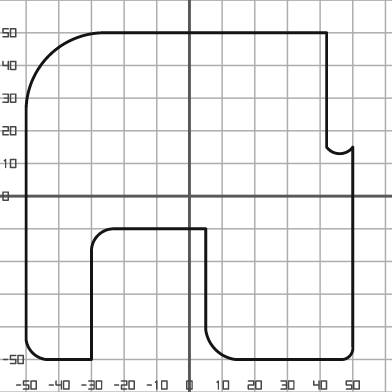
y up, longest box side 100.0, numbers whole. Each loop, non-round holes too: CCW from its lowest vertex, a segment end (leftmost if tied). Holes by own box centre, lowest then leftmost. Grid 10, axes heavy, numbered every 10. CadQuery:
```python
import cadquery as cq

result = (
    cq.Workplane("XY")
    .moveTo(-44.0, -50.0)
    .lineTo(-30.0, -50.0)
    .lineTo(-30.0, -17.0)
    .threePointArc((-28.0, -12.0), (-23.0, -10.0))
    .lineTo(5.0, -10.0)
    .lineTo(5.0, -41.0)
    .threePointArc((8.0, -47.0), (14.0, -50.0))
    .lineTo(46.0, -50.0)
    .threePointArc((49.0, -49.0), (50.0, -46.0))
    .lineTo(50.0, 15.0)
    .threePointArc((46.0, 13.0), (42.0, 15.0))
    .lineTo(42.0, 50.0)
    .lineTo(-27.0, 50.0)
    .threePointArc((-43.0, 43.0), (-50.0, 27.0))
    .lineTo(-50.0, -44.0)
    .threePointArc((-48.0, -48.0), (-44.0, -50.0))
    .close()
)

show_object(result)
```